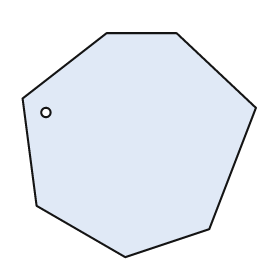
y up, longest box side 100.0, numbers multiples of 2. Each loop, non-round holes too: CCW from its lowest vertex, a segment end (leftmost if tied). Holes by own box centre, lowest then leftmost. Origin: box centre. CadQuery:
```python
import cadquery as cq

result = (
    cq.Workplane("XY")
    .moveTo(-6.0, -48.0)
    .lineTo(30.0, -36.0)
    .lineTo(50.0, 16.0)
    .lineTo(16.0, 48.0)
    .lineTo(-14.0, 48.0)
    .lineTo(-50.0, 20.0)
    .lineTo(-44.0, -26.0)
    .close()
    .moveTo(-40.0, 14.0)
    .circle(2.0)
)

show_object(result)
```